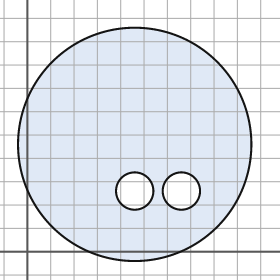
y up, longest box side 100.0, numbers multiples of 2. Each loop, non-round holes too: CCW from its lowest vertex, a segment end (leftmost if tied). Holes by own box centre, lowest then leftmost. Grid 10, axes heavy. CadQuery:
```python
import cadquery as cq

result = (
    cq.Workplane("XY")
    .moveTo(46.0, 46.0)
    .circle(50.0)
    .moveTo(46.0, 26.0)
    .circle(8.0)
    .moveTo(66.0, 26.0)
    .circle(8.0)
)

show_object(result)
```